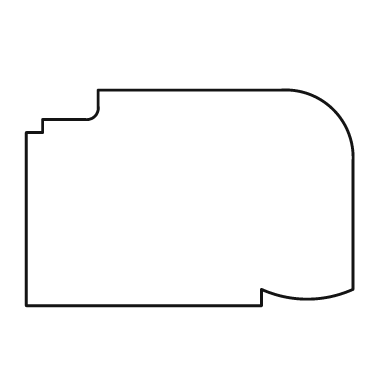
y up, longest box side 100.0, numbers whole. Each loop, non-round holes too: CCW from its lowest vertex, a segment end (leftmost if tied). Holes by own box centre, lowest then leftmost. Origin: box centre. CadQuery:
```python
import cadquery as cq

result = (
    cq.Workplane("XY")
    .moveTo(-50.0, -33.0)
    .lineTo(22.0, -33.0)
    .lineTo(22.0, -28.0)
    .threePointArc((36.0, -31.0), (50.0, -28.0))
    .lineTo(50.0, 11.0)
    .threePointArc((44.0, 27.0), (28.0, 33.0))
    .lineTo(-28.0, 33.0)
    .lineTo(-28.0, 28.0)
    .threePointArc((-29.0, 25.0), (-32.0, 24.0))
    .lineTo(-45.0, 24.0)
    .lineTo(-45.0, 20.0)
    .lineTo(-50.0, 20.0)
    .close()
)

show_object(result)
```